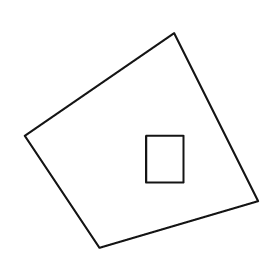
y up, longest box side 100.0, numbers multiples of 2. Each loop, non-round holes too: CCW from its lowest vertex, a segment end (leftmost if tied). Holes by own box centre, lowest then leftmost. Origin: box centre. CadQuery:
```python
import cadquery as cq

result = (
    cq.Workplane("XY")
    .moveTo(-18.0, -46.0)
    .lineTo(50.0, -26.0)
    .lineTo(14.0, 46.0)
    .lineTo(-50.0, 2.0)
    .close()
    .moveTo(2.0, -18.0)
    .lineTo(18.0, -18.0)
    .lineTo(18.0, 2.0)
    .lineTo(2.0, 2.0)
    .close()
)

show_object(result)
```